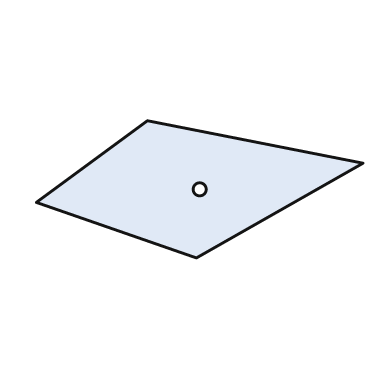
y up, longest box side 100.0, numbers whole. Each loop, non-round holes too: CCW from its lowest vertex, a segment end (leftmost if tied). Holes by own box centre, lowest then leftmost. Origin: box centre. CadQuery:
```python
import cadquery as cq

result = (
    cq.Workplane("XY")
    .moveTo(-1.0, -21.0)
    .lineTo(50.0, 8.0)
    .lineTo(-16.0, 21.0)
    .lineTo(-50.0, -4.0)
    .close()
    .moveTo(0.0, 0.0)
    .circle(2.0)
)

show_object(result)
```